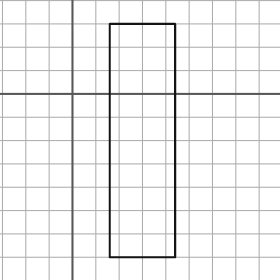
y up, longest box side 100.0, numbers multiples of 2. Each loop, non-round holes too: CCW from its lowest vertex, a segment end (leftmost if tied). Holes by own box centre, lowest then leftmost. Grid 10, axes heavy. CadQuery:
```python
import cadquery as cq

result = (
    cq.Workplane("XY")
    .moveTo(16.0, -70.0)
    .lineTo(44.0, -70.0)
    .lineTo(44.0, 30.0)
    .lineTo(16.0, 30.0)
    .close()
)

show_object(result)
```